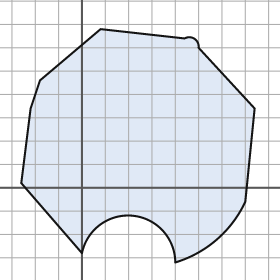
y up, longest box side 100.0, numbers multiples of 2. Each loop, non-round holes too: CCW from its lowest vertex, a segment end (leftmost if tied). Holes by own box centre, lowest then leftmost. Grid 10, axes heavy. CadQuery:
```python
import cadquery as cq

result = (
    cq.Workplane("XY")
    .moveTo(40.0, -32.0)
    .threePointArc((58.0, -22.0), (70.0, -6.0))
    .lineTo(74.0, 34.0)
    .lineTo(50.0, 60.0)
    .threePointArc((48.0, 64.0), (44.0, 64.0))
    .lineTo(8.0, 68.0)
    .lineTo(-18.0, 46.0)
    .lineTo(-22.0, 34.0)
    .lineTo(-26.0, 2.0)
    .lineTo(0.0, -28.0)
    .threePointArc((22.0, -12.0), (40.0, -32.0))
    .close()
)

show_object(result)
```